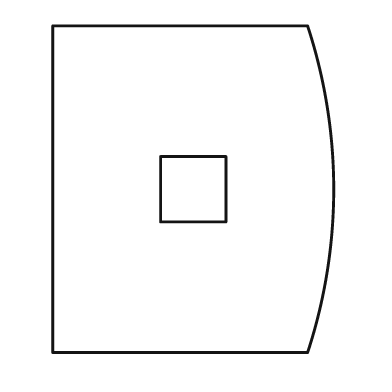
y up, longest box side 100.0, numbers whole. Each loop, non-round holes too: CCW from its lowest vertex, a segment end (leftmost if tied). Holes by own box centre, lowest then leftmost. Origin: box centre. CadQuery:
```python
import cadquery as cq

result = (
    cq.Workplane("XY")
    .moveTo(-43.0, -50.0)
    .lineTo(35.0, -50.0)
    .threePointArc((43.0, 0.0), (35.0, 50.0))
    .lineTo(-43.0, 50.0)
    .close()
    .moveTo(-10.0, -10.0)
    .lineTo(10.0, -10.0)
    .lineTo(10.0, 10.0)
    .lineTo(-10.0, 10.0)
    .close()
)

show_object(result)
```